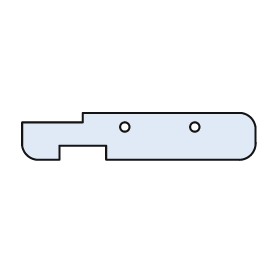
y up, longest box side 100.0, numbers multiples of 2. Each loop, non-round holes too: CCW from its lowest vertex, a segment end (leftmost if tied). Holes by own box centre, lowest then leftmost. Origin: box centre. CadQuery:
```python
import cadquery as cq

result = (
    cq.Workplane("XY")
    .moveTo(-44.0, -10.0)
    .lineTo(-34.0, -10.0)
    .lineTo(-34.0, -4.0)
    .lineTo(-14.0, -4.0)
    .lineTo(-14.0, -10.0)
    .lineTo(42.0, -10.0)
    .threePointArc((48.0, -8.0), (50.0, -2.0))
    .lineTo(50.0, 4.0)
    .threePointArc((48.0, 8.0), (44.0, 10.0))
    .lineTo(-24.0, 10.0)
    .lineTo(-24.0, 6.0)
    .lineTo(-50.0, 6.0)
    .lineTo(-50.0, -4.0)
    .threePointArc((-48.0, -8.0), (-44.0, -10.0))
    .close()
    .moveTo(-6.0, 4.0)
    .circle(2.0)
    .moveTo(24.0, 4.0)
    .circle(2.0)
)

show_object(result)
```